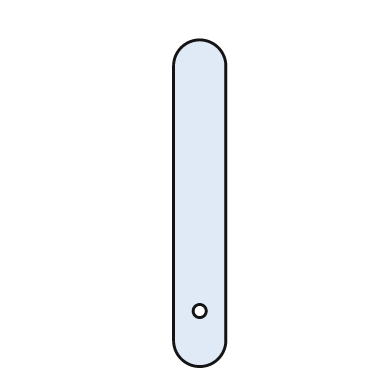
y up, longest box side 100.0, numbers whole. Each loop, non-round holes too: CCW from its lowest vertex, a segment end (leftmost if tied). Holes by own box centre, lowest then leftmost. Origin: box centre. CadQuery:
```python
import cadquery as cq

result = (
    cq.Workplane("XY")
    .moveTo(-8.0, -42.0)
    .threePointArc((0.0, -50.0), (8.0, -42.0))
    .lineTo(8.0, 42.0)
    .threePointArc((0.0, 50.0), (-8.0, 42.0))
    .close()
    .moveTo(0.0, -33.0)
    .circle(2.0)
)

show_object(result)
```